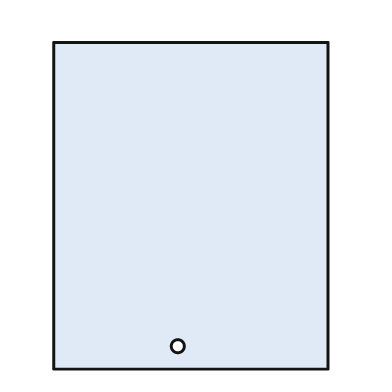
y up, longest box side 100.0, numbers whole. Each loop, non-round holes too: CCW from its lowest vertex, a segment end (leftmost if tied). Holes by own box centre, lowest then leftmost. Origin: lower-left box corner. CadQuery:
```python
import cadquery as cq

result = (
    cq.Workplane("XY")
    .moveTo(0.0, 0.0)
    .lineTo(84.0, 0.0)
    .lineTo(84.0, 100.0)
    .lineTo(0.0, 100.0)
    .close()
    .moveTo(38.0, 7.0)
    .circle(2.0)
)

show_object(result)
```